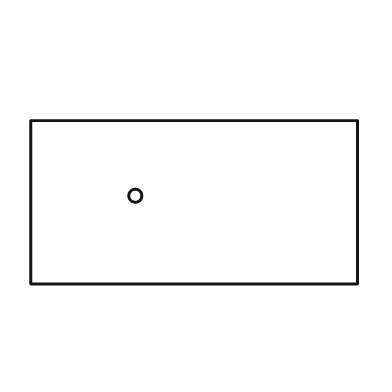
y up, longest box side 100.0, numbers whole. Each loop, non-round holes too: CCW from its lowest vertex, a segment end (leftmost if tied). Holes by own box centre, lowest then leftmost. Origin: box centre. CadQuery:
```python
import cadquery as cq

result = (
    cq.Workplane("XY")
    .moveTo(-50.0, -25.0)
    .lineTo(50.0, -25.0)
    .lineTo(50.0, 25.0)
    .lineTo(-50.0, 25.0)
    .close()
    .moveTo(-18.0, 2.0)
    .circle(2.0)
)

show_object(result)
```